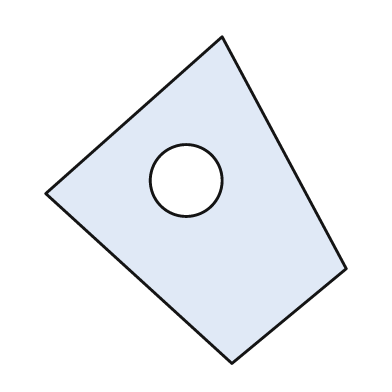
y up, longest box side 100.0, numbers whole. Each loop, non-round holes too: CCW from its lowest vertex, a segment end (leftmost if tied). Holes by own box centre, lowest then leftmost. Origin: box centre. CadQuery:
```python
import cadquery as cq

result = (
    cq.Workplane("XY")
    .moveTo(11.0, -50.0)
    .lineTo(46.0, -21.0)
    .lineTo(8.0, 50.0)
    .lineTo(-46.0, 2.0)
    .close()
    .moveTo(-3.0, 6.0)
    .circle(11.0)
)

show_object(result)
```